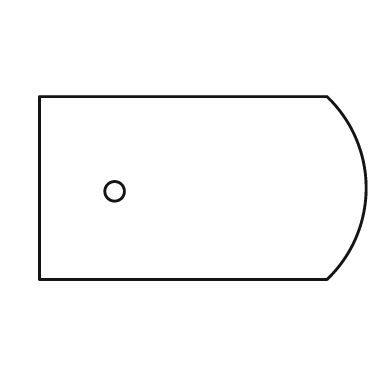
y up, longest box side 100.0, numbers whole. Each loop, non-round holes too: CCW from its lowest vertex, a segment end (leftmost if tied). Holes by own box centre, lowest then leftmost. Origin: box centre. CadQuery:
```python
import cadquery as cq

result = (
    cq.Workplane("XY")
    .moveTo(-50.0, -28.0)
    .lineTo(38.0, -28.0)
    .threePointArc((50.0, 0.0), (38.0, 28.0))
    .lineTo(-50.0, 28.0)
    .close()
    .moveTo(-27.0, -1.0)
    .circle(3.0)
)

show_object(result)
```